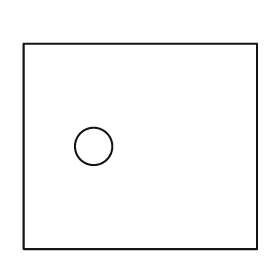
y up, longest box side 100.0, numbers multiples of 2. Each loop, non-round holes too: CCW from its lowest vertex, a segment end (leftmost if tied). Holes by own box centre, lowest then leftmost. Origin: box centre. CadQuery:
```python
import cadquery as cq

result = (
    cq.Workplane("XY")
    .moveTo(-50.0, -44.0)
    .lineTo(50.0, -44.0)
    .lineTo(50.0, 44.0)
    .lineTo(-50.0, 44.0)
    .close()
    .moveTo(-20.0, 0.0)
    .circle(8.0)
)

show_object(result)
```